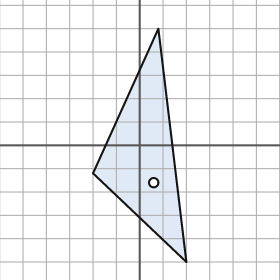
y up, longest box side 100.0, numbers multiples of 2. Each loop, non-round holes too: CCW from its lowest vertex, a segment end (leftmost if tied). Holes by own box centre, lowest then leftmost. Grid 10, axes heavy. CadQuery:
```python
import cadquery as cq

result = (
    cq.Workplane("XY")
    .moveTo(20.0, -50.0)
    .lineTo(8.0, 50.0)
    .lineTo(-20.0, -12.0)
    .close()
    .moveTo(6.0, -16.0)
    .circle(2.0)
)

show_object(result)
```